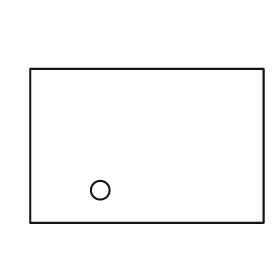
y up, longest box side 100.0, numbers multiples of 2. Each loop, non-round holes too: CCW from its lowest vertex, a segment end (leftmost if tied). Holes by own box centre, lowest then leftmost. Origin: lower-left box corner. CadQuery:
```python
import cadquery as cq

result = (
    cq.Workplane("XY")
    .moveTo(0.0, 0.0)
    .lineTo(100.0, 0.0)
    .lineTo(100.0, 66.0)
    .lineTo(0.0, 66.0)
    .close()
    .moveTo(30.0, 14.0)
    .circle(4.0)
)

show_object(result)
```